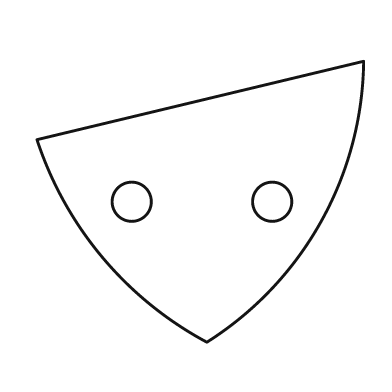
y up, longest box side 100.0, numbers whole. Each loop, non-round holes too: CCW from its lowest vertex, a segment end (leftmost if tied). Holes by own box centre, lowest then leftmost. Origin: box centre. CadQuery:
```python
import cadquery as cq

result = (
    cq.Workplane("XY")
    .moveTo(2.0, -43.0)
    .threePointArc((37.0, -6.0), (50.0, 43.0))
    .lineTo(-50.0, 19.0)
    .threePointArc((-30.0, -17.0), (2.0, -43.0))
    .close()
    .moveTo(-21.0, 0.0)
    .circle(6.0)
    .moveTo(22.0, 0.0)
    .circle(6.0)
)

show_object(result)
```